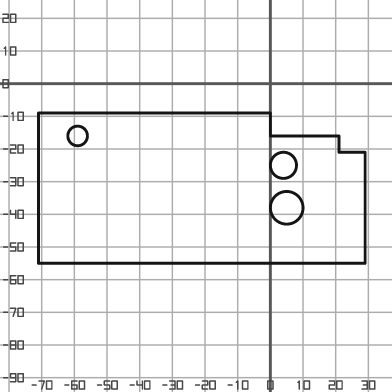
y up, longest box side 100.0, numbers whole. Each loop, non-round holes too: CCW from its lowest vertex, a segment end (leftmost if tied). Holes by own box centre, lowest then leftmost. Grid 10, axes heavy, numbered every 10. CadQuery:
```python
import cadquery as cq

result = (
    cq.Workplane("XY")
    .moveTo(-71.0, -55.0)
    .lineTo(29.0, -55.0)
    .lineTo(29.0, -21.0)
    .lineTo(21.0, -21.0)
    .lineTo(21.0, -16.0)
    .lineTo(0.0, -16.0)
    .lineTo(0.0, -9.0)
    .lineTo(-71.0, -9.0)
    .close()
    .moveTo(5.0, -38.0)
    .circle(5.0)
    .moveTo(4.0, -25.0)
    .circle(4.0)
    .moveTo(-59.0, -16.0)
    .circle(3.0)
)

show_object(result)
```